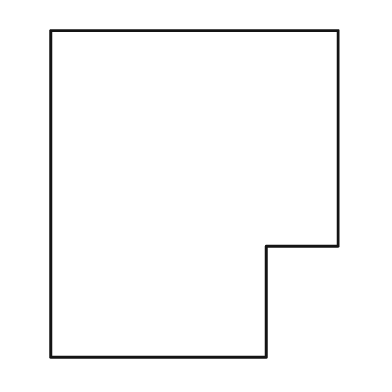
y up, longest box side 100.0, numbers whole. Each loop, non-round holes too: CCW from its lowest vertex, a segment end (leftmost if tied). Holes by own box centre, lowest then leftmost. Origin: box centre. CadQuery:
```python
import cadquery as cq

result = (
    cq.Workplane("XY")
    .moveTo(-44.0, -50.0)
    .lineTo(22.0, -50.0)
    .lineTo(22.0, -16.0)
    .lineTo(44.0, -16.0)
    .lineTo(44.0, 50.0)
    .lineTo(-44.0, 50.0)
    .close()
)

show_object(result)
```